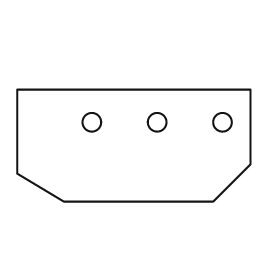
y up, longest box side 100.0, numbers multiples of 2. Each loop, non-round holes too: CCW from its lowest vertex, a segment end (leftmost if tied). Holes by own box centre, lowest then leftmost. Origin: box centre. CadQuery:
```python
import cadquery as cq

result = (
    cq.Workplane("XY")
    .moveTo(-30.0, -24.0)
    .lineTo(34.0, -24.0)
    .lineTo(50.0, -8.0)
    .lineTo(50.0, 24.0)
    .lineTo(-50.0, 24.0)
    .lineTo(-50.0, -12.0)
    .close()
    .moveTo(-18.0, 10.0)
    .circle(4.0)
    .moveTo(10.0, 10.0)
    .circle(4.0)
    .moveTo(38.0, 10.0)
    .circle(4.0)
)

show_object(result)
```